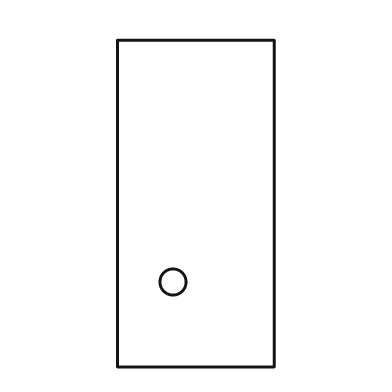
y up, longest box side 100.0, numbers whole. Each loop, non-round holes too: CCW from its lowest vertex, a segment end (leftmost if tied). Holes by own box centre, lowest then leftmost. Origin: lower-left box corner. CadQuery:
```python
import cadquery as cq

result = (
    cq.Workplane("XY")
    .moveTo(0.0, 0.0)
    .lineTo(48.0, 0.0)
    .lineTo(48.0, 100.0)
    .lineTo(0.0, 100.0)
    .close()
    .moveTo(17.0, 26.0)
    .circle(4.0)
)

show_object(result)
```